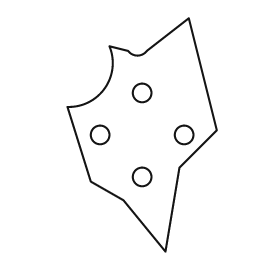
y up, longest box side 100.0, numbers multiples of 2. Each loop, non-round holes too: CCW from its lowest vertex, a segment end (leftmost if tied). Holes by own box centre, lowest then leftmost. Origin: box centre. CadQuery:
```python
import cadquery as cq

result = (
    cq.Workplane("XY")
    .moveTo(10.0, -50.0)
    .lineTo(16.0, -14.0)
    .lineTo(32.0, 2.0)
    .lineTo(20.0, 50.0)
    .lineTo(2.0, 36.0)
    .threePointArc((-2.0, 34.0), (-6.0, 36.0))
    .lineTo(-14.0, 38.0)
    .threePointArc((-16.0, 20.0), (-32.0, 12.0))
    .lineTo(-22.0, -20.0)
    .lineTo(-8.0, -28.0)
    .close()
    .moveTo(0.0, -18.0)
    .circle(4.0)
    .moveTo(-18.0, 0.0)
    .circle(4.0)
    .moveTo(18.0, 0.0)
    .circle(4.0)
    .moveTo(0.0, 18.0)
    .circle(4.0)
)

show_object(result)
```